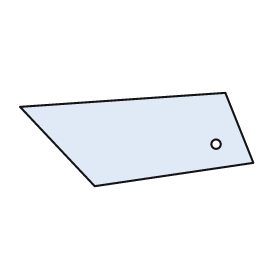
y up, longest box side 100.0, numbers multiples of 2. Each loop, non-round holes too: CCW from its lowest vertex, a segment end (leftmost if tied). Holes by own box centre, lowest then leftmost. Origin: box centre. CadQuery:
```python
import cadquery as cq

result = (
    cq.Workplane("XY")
    .moveTo(-18.0, -20.0)
    .lineTo(50.0, -10.0)
    .lineTo(38.0, 20.0)
    .lineTo(-50.0, 14.0)
    .close()
    .moveTo(34.0, -2.0)
    .circle(2.0)
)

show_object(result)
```